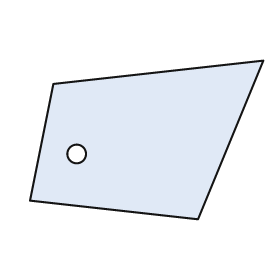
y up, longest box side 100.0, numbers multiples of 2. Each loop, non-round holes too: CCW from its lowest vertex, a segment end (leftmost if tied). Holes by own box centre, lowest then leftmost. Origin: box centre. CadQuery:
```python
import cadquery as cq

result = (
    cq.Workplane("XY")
    .moveTo(22.0, -34.0)
    .lineTo(50.0, 34.0)
    .lineTo(-40.0, 24.0)
    .lineTo(-50.0, -26.0)
    .close()
    .moveTo(-30.0, -6.0)
    .circle(4.0)
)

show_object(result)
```